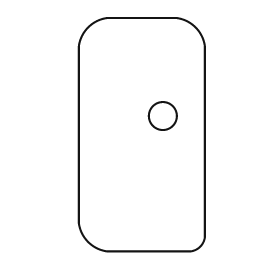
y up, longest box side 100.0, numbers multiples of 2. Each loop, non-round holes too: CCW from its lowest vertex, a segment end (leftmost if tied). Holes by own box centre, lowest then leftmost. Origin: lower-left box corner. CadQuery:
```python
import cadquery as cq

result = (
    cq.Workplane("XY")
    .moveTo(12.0, 0.0)
    .lineTo(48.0, 0.0)
    .threePointArc((52.0, 2.0), (54.0, 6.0))
    .lineTo(54.0, 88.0)
    .threePointArc((50.0, 96.0), (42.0, 100.0))
    .lineTo(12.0, 100.0)
    .threePointArc((4.0, 96.0), (0.0, 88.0))
    .lineTo(0.0, 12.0)
    .threePointArc((4.0, 4.0), (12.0, 0.0))
    .close()
    .moveTo(36.0, 58.0)
    .circle(6.0)
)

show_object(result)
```